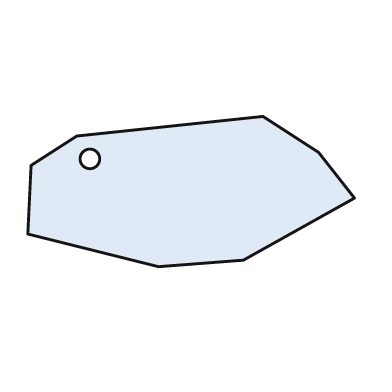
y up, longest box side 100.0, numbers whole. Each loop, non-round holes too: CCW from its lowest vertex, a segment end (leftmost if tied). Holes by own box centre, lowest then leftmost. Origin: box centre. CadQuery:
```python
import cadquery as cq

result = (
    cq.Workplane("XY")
    .moveTo(-10.0, -23.0)
    .lineTo(16.0, -21.0)
    .lineTo(50.0, -2.0)
    .lineTo(39.0, 12.0)
    .lineTo(22.0, 23.0)
    .lineTo(-35.0, 17.0)
    .lineTo(-49.0, 8.0)
    .lineTo(-50.0, -13.0)
    .close()
    .moveTo(-31.0, 10.0)
    .circle(3.0)
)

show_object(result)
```